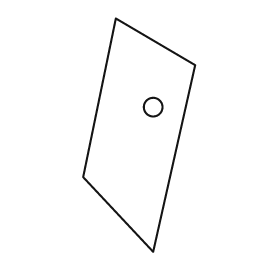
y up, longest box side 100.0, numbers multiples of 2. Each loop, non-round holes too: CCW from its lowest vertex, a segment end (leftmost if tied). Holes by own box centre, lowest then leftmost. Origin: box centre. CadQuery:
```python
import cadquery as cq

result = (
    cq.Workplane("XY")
    .moveTo(6.0, -50.0)
    .lineTo(24.0, 30.0)
    .lineTo(-10.0, 50.0)
    .lineTo(-24.0, -18.0)
    .close()
    .moveTo(6.0, 12.0)
    .circle(4.0)
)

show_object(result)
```